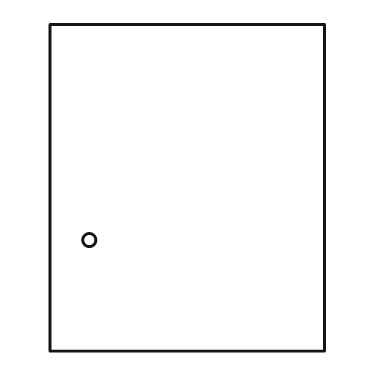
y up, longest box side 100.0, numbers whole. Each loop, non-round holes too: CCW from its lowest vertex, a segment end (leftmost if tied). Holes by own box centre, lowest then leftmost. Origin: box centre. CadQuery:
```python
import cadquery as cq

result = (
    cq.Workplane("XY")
    .moveTo(-42.0, -50.0)
    .lineTo(42.0, -50.0)
    .lineTo(42.0, 50.0)
    .lineTo(-42.0, 50.0)
    .close()
    .moveTo(-30.0, -16.0)
    .circle(2.0)
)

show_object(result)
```